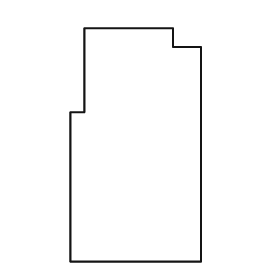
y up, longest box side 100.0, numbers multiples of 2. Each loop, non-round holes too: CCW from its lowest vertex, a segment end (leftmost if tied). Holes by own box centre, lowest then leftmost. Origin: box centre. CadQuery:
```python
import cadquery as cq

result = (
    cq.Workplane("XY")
    .moveTo(-28.0, -50.0)
    .lineTo(28.0, -50.0)
    .lineTo(28.0, 42.0)
    .lineTo(16.0, 42.0)
    .lineTo(16.0, 50.0)
    .lineTo(-22.0, 50.0)
    .lineTo(-22.0, 14.0)
    .lineTo(-28.0, 14.0)
    .close()
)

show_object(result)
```